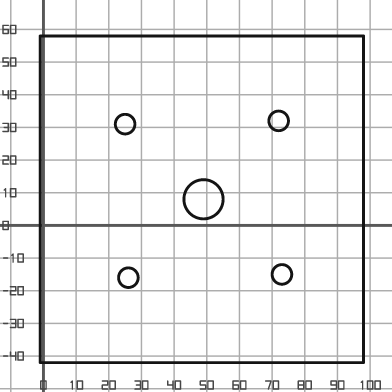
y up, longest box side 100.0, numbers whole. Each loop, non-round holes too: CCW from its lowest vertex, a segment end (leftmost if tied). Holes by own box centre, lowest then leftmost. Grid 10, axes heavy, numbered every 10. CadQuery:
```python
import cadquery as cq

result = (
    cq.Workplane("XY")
    .moveTo(-1.0, -42.0)
    .lineTo(98.0, -42.0)
    .lineTo(98.0, 58.0)
    .lineTo(-1.0, 58.0)
    .close()
    .moveTo(26.0, -16.0)
    .circle(3.0)
    .moveTo(73.0, -15.0)
    .circle(3.0)
    .moveTo(49.0, 8.0)
    .circle(6.0)
    .moveTo(25.0, 31.0)
    .circle(3.0)
    .moveTo(72.0, 32.0)
    .circle(3.0)
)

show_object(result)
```